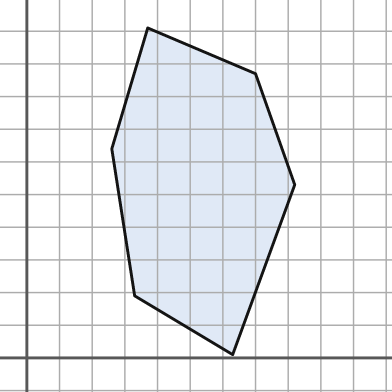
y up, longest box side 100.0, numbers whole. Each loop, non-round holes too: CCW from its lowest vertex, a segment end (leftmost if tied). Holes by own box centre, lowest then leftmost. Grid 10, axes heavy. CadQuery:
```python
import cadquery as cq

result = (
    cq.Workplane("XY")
    .moveTo(63.0, 1.0)
    .lineTo(82.0, 53.0)
    .lineTo(70.0, 87.0)
    .lineTo(37.0, 101.0)
    .lineTo(26.0, 64.0)
    .lineTo(33.0, 19.0)
    .close()
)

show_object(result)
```